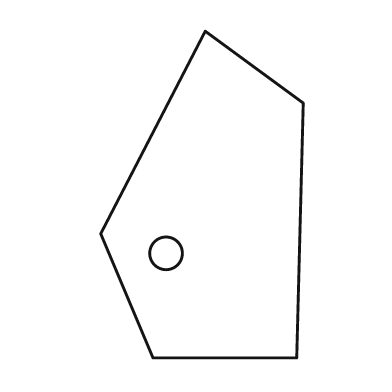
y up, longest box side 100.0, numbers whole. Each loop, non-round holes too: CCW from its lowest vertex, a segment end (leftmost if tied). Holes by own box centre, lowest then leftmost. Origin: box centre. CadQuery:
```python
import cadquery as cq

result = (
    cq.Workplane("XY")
    .moveTo(-15.0, -50.0)
    .lineTo(29.0, -50.0)
    .lineTo(31.0, 28.0)
    .lineTo(1.0, 50.0)
    .lineTo(-31.0, -12.0)
    .close()
    .moveTo(-11.0, -18.0)
    .circle(5.0)
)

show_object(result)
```